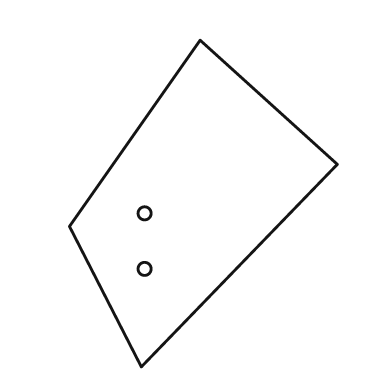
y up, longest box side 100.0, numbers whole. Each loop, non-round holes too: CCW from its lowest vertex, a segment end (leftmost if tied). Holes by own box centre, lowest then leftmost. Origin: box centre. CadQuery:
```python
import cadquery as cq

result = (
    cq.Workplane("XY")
    .moveTo(-19.0, -50.0)
    .lineTo(41.0, 12.0)
    .lineTo(-1.0, 50.0)
    .lineTo(-41.0, -7.0)
    .close()
    .moveTo(-18.0, -20.0)
    .circle(2.0)
    .moveTo(-18.0, -3.0)
    .circle(2.0)
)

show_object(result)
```